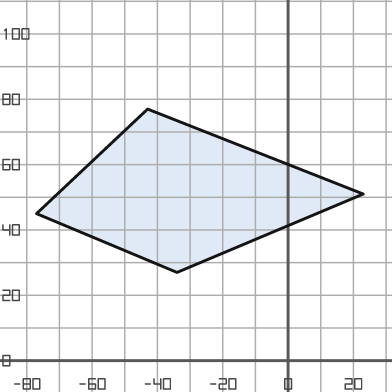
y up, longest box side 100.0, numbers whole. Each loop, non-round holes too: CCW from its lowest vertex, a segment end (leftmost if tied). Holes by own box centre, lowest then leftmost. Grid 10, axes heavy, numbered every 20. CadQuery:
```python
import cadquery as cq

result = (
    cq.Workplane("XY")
    .moveTo(-34.0, 27.0)
    .lineTo(23.0, 51.0)
    .lineTo(-43.0, 77.0)
    .lineTo(-77.0, 45.0)
    .close()
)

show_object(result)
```